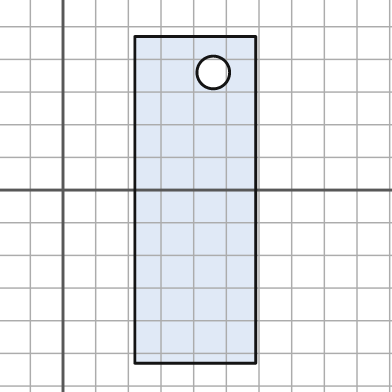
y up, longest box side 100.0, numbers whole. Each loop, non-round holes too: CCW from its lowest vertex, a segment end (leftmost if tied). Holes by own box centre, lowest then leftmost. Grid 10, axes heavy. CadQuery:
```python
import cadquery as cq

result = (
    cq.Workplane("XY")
    .moveTo(22.0, -53.0)
    .lineTo(59.0, -53.0)
    .lineTo(59.0, 47.0)
    .lineTo(22.0, 47.0)
    .close()
    .moveTo(46.0, 36.0)
    .circle(5.0)
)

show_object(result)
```